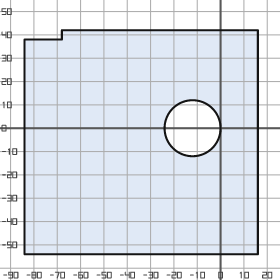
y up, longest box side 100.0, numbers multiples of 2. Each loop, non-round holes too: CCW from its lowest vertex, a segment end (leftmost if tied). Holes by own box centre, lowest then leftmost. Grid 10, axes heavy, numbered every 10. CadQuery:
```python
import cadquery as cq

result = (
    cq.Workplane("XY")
    .moveTo(-84.0, -54.0)
    .lineTo(16.0, -54.0)
    .lineTo(16.0, 42.0)
    .lineTo(-68.0, 42.0)
    .lineTo(-68.0, 38.0)
    .lineTo(-84.0, 38.0)
    .close()
    .moveTo(-12.0, 0.0)
    .circle(12.0)
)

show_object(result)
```